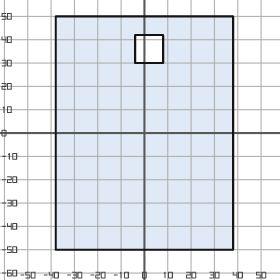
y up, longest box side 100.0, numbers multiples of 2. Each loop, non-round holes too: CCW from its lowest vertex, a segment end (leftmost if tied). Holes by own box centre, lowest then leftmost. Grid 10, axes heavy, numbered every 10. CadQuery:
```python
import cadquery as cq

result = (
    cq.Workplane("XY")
    .moveTo(-38.0, -50.0)
    .lineTo(38.0, -50.0)
    .lineTo(38.0, 50.0)
    .lineTo(-38.0, 50.0)
    .close()
    .moveTo(-4.0, 30.0)
    .lineTo(8.0, 30.0)
    .lineTo(8.0, 42.0)
    .lineTo(-4.0, 42.0)
    .close()
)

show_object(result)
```